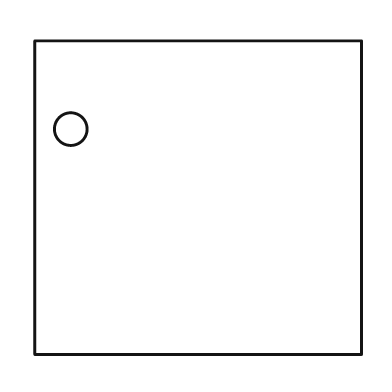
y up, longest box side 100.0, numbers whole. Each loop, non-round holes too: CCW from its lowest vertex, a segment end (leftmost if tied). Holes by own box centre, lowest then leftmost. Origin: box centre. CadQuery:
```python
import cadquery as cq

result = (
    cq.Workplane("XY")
    .moveTo(-50.0, -48.0)
    .lineTo(50.0, -48.0)
    .lineTo(50.0, 48.0)
    .lineTo(-50.0, 48.0)
    .close()
    .moveTo(-39.0, 21.0)
    .circle(5.0)
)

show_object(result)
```